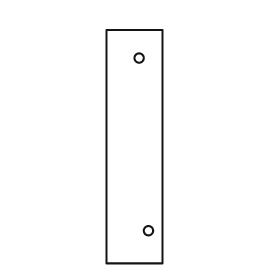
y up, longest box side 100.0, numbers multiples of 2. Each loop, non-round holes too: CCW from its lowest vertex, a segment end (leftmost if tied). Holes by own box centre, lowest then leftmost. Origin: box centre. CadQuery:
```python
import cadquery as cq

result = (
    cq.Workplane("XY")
    .moveTo(-12.0, -50.0)
    .lineTo(12.0, -50.0)
    .lineTo(12.0, 50.0)
    .lineTo(-12.0, 50.0)
    .close()
    .moveTo(6.0, -36.0)
    .circle(2.0)
    .moveTo(2.0, 38.0)
    .circle(2.0)
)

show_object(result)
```